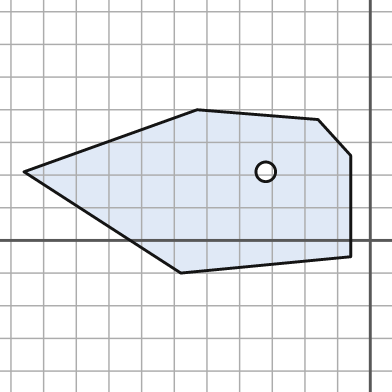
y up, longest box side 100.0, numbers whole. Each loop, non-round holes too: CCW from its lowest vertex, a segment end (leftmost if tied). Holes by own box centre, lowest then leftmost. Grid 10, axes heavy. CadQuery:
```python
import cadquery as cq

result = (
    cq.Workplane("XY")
    .moveTo(-58.0, -10.0)
    .lineTo(-6.0, -5.0)
    .lineTo(-6.0, 26.0)
    .lineTo(-16.0, 37.0)
    .lineTo(-53.0, 40.0)
    .lineTo(-106.0, 21.0)
    .close()
    .moveTo(-32.0, 21.0)
    .circle(3.0)
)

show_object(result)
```